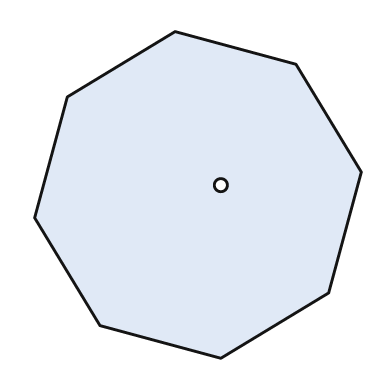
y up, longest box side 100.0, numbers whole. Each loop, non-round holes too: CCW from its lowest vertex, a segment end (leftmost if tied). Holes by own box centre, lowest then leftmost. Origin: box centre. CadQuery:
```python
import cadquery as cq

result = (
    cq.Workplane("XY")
    .moveTo(7.0, -50.0)
    .lineTo(40.0, -30.0)
    .lineTo(50.0, 7.0)
    .lineTo(30.0, 40.0)
    .lineTo(-7.0, 50.0)
    .lineTo(-40.0, 30.0)
    .lineTo(-50.0, -7.0)
    .lineTo(-30.0, -40.0)
    .close()
    .moveTo(7.0, 3.0)
    .circle(2.0)
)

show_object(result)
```